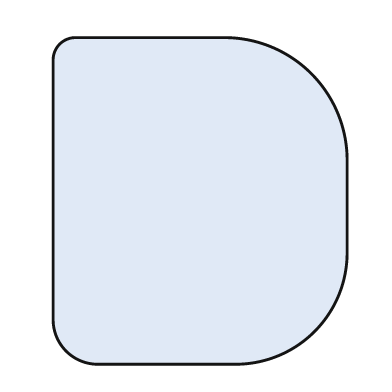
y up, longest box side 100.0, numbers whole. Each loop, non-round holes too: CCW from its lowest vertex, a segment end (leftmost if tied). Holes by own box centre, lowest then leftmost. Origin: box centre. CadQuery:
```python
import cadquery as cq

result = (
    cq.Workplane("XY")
    .moveTo(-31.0, -50.0)
    .lineTo(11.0, -50.0)
    .threePointArc((35.0, -40.0), (45.0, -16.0))
    .lineTo(45.0, 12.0)
    .threePointArc((34.0, 39.0), (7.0, 50.0))
    .lineTo(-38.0, 50.0)
    .threePointArc((-43.0, 48.0), (-45.0, 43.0))
    .lineTo(-45.0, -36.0)
    .threePointArc((-41.0, -46.0), (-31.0, -50.0))
    .close()
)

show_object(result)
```